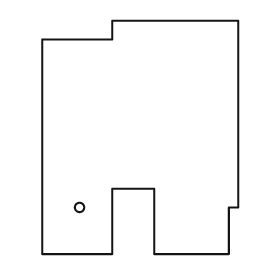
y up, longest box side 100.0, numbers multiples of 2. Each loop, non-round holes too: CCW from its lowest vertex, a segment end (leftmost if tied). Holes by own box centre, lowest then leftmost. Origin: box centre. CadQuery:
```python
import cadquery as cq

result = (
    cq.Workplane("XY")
    .moveTo(-42.0, -50.0)
    .lineTo(-12.0, -50.0)
    .lineTo(-12.0, -22.0)
    .lineTo(6.0, -22.0)
    .lineTo(6.0, -50.0)
    .lineTo(38.0, -50.0)
    .lineTo(38.0, -30.0)
    .lineTo(42.0, -30.0)
    .lineTo(42.0, 50.0)
    .lineTo(-12.0, 50.0)
    .lineTo(-12.0, 42.0)
    .lineTo(-42.0, 42.0)
    .close()
    .moveTo(-26.0, -30.0)
    .circle(2.0)
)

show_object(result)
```